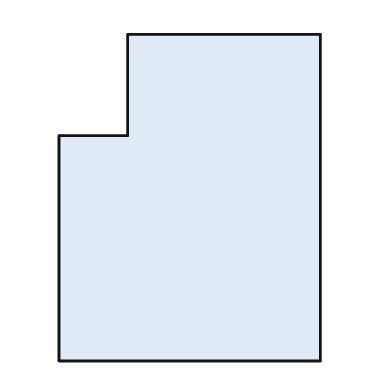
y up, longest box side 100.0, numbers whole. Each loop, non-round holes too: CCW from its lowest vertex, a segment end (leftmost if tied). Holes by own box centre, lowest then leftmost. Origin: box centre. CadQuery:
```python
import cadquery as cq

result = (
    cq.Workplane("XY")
    .moveTo(-40.0, -50.0)
    .lineTo(40.0, -50.0)
    .lineTo(40.0, 50.0)
    .lineTo(-19.0, 50.0)
    .lineTo(-19.0, 19.0)
    .lineTo(-40.0, 19.0)
    .close()
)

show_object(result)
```